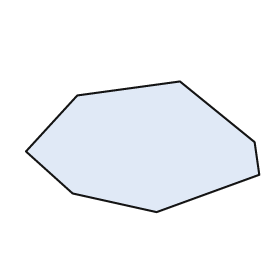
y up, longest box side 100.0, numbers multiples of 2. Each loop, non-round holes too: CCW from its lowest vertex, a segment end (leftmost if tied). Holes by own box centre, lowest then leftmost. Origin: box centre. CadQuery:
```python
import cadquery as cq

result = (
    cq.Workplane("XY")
    .moveTo(6.0, -28.0)
    .lineTo(50.0, -12.0)
    .lineTo(48.0, 2.0)
    .lineTo(16.0, 28.0)
    .lineTo(-28.0, 22.0)
    .lineTo(-50.0, -2.0)
    .lineTo(-30.0, -20.0)
    .close()
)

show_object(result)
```